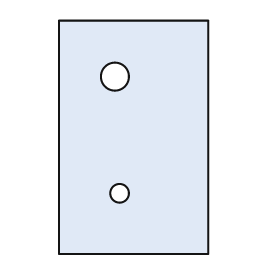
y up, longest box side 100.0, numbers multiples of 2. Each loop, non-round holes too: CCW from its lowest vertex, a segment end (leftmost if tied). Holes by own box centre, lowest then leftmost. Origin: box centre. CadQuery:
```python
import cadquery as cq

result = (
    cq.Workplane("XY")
    .moveTo(-32.0, -50.0)
    .lineTo(32.0, -50.0)
    .lineTo(32.0, 50.0)
    .lineTo(-32.0, 50.0)
    .close()
    .moveTo(-6.0, -24.0)
    .circle(4.0)
    .moveTo(-8.0, 26.0)
    .circle(6.0)
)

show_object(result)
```